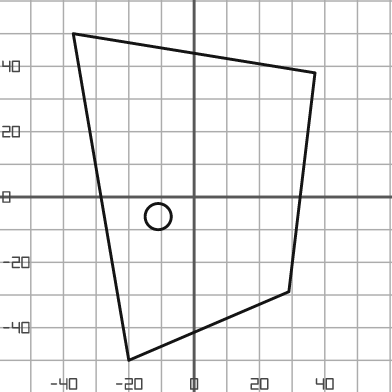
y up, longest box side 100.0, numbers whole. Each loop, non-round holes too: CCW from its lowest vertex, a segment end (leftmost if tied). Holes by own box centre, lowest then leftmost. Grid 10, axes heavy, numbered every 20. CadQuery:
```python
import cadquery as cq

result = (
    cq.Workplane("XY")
    .moveTo(-20.0, -50.0)
    .lineTo(29.0, -29.0)
    .lineTo(37.0, 38.0)
    .lineTo(-37.0, 50.0)
    .close()
    .moveTo(-11.0, -6.0)
    .circle(4.0)
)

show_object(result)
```